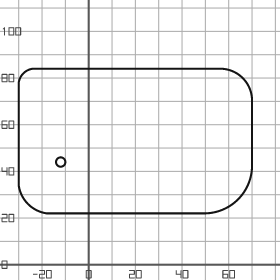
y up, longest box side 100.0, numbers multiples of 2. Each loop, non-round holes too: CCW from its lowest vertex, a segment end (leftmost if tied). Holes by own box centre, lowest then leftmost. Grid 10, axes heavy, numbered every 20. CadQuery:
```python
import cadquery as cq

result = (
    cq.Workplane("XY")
    .moveTo(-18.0, 22.0)
    .lineTo(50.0, 22.0)
    .threePointArc((64.0, 28.0), (70.0, 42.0))
    .lineTo(70.0, 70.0)
    .threePointArc((66.0, 80.0), (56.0, 84.0))
    .lineTo(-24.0, 84.0)
    .threePointArc((-28.0, 82.0), (-30.0, 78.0))
    .lineTo(-30.0, 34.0)
    .threePointArc((-26.0, 26.0), (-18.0, 22.0))
    .close()
    .moveTo(-12.0, 44.0)
    .circle(2.0)
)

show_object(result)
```